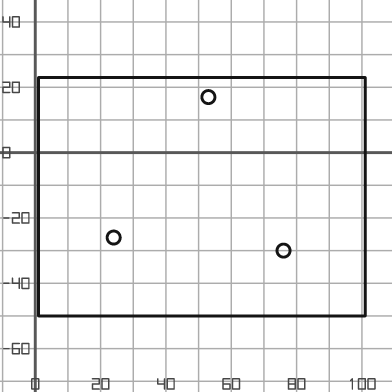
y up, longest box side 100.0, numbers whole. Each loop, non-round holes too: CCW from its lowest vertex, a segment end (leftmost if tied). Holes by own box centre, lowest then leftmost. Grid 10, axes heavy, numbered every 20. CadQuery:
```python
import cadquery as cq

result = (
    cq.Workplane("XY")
    .moveTo(1.0, -50.0)
    .lineTo(101.0, -50.0)
    .lineTo(101.0, 23.0)
    .lineTo(1.0, 23.0)
    .close()
    .moveTo(76.0, -30.0)
    .circle(2.0)
    .moveTo(24.0, -26.0)
    .circle(2.0)
    .moveTo(53.0, 17.0)
    .circle(2.0)
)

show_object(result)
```